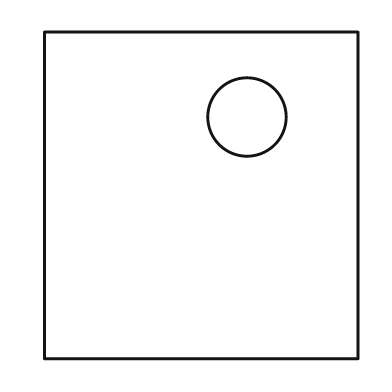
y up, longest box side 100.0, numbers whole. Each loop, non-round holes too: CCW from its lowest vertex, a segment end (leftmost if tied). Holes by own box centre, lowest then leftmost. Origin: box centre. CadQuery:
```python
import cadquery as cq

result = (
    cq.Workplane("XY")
    .moveTo(-48.0, -50.0)
    .lineTo(48.0, -50.0)
    .lineTo(48.0, 50.0)
    .lineTo(-48.0, 50.0)
    .close()
    .moveTo(14.0, 24.0)
    .circle(12.0)
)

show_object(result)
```